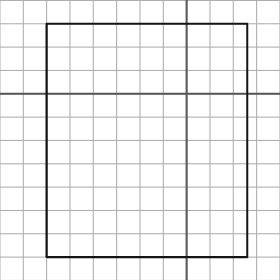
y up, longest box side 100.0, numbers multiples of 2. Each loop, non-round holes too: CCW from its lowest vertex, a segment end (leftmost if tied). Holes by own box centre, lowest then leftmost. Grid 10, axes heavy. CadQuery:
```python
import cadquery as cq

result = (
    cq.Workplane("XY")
    .moveTo(-60.0, -70.0)
    .lineTo(26.0, -70.0)
    .lineTo(26.0, 30.0)
    .lineTo(-60.0, 30.0)
    .close()
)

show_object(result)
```